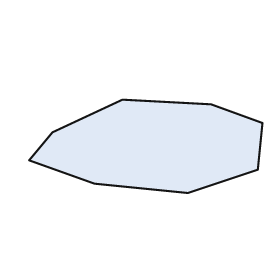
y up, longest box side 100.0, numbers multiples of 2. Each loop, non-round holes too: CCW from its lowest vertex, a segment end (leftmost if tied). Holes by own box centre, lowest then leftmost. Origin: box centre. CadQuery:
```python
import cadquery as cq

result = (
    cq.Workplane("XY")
    .moveTo(18.0, -20.0)
    .lineTo(48.0, -10.0)
    .lineTo(50.0, 10.0)
    .lineTo(28.0, 18.0)
    .lineTo(-10.0, 20.0)
    .lineTo(-40.0, 6.0)
    .lineTo(-50.0, -6.0)
    .lineTo(-22.0, -16.0)
    .close()
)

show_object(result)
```